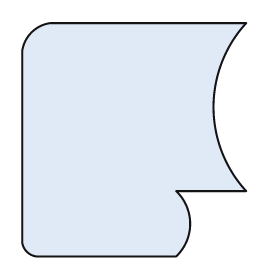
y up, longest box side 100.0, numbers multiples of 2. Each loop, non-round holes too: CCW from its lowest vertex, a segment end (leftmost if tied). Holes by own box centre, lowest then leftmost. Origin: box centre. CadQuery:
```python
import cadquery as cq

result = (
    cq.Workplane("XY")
    .moveTo(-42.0, -50.0)
    .lineTo(18.0, -50.0)
    .threePointArc((24.0, -36.0), (18.0, -22.0))
    .lineTo(48.0, -22.0)
    .threePointArc((34.0, 14.0), (48.0, 50.0))
    .lineTo(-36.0, 50.0)
    .threePointArc((-44.0, 46.0), (-48.0, 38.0))
    .lineTo(-48.0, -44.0)
    .threePointArc((-46.0, -48.0), (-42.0, -50.0))
    .close()
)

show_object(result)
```